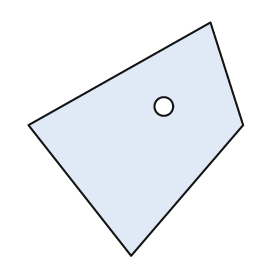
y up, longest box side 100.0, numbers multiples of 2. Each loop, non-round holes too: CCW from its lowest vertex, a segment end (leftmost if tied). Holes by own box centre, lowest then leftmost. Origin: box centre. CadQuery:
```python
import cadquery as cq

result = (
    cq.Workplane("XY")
    .moveTo(-2.0, -50.0)
    .lineTo(46.0, 6.0)
    .lineTo(32.0, 50.0)
    .lineTo(-46.0, 6.0)
    .close()
    .moveTo(12.0, 14.0)
    .circle(4.0)
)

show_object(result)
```